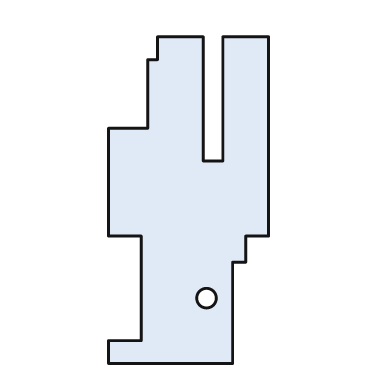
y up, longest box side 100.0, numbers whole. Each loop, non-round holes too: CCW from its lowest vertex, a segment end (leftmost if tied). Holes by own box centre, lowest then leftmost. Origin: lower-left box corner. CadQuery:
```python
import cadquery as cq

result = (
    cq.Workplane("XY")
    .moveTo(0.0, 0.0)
    .lineTo(38.0, 0.0)
    .lineTo(38.0, 31.0)
    .lineTo(42.0, 31.0)
    .lineTo(42.0, 39.0)
    .lineTo(49.0, 39.0)
    .lineTo(49.0, 100.0)
    .lineTo(35.0, 100.0)
    .lineTo(35.0, 62.0)
    .lineTo(29.0, 62.0)
    .lineTo(29.0, 100.0)
    .lineTo(15.0, 100.0)
    .lineTo(15.0, 93.0)
    .lineTo(12.0, 93.0)
    .lineTo(12.0, 72.0)
    .lineTo(0.0, 72.0)
    .lineTo(0.0, 39.0)
    .lineTo(10.0, 39.0)
    .lineTo(10.0, 7.0)
    .lineTo(0.0, 7.0)
    .close()
    .moveTo(30.0, 20.0)
    .circle(3.0)
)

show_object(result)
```